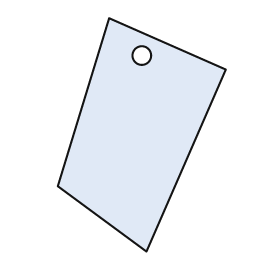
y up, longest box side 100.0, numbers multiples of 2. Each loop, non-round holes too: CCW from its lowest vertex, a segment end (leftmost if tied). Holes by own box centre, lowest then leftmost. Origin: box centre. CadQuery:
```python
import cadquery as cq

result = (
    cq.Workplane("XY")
    .moveTo(2.0, -50.0)
    .lineTo(36.0, 28.0)
    .lineTo(-14.0, 50.0)
    .lineTo(-36.0, -22.0)
    .close()
    .moveTo(0.0, 34.0)
    .circle(4.0)
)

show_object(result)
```